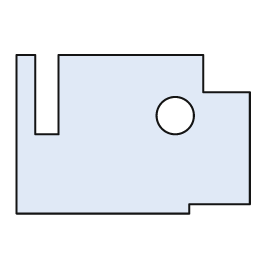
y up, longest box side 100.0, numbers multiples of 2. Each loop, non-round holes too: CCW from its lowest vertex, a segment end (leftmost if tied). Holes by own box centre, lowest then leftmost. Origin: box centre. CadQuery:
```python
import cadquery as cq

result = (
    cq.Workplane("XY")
    .moveTo(-50.0, -34.0)
    .lineTo(24.0, -34.0)
    .lineTo(24.0, -30.0)
    .lineTo(50.0, -30.0)
    .lineTo(50.0, 18.0)
    .lineTo(30.0, 18.0)
    .lineTo(30.0, 34.0)
    .lineTo(-32.0, 34.0)
    .lineTo(-32.0, 0.0)
    .lineTo(-42.0, 0.0)
    .lineTo(-42.0, 34.0)
    .lineTo(-50.0, 34.0)
    .close()
    .moveTo(18.0, 8.0)
    .circle(8.0)
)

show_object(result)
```